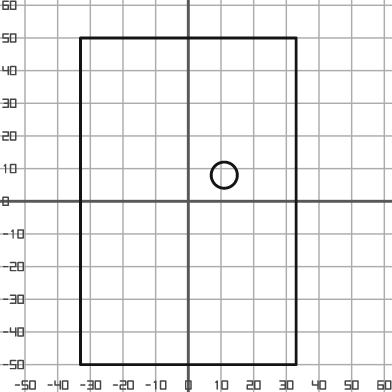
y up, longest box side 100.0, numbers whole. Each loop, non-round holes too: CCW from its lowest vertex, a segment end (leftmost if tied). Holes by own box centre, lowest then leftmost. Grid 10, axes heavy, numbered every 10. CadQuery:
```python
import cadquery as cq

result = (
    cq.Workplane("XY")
    .moveTo(-33.0, -50.0)
    .lineTo(33.0, -50.0)
    .lineTo(33.0, 50.0)
    .lineTo(-33.0, 50.0)
    .close()
    .moveTo(11.0, 8.0)
    .circle(4.0)
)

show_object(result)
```